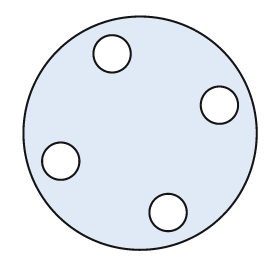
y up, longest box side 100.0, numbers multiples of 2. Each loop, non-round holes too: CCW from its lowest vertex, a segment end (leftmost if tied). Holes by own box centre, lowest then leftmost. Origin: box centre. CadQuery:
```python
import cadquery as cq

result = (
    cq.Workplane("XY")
    .moveTo(0.0, 0.0)
    .circle(50.0)
    .moveTo(12.0, -34.0)
    .circle(8.0)
    .moveTo(-34.0, -12.0)
    .circle(8.0)
    .moveTo(34.0, 12.0)
    .circle(8.0)
    .moveTo(-12.0, 34.0)
    .circle(8.0)
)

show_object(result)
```